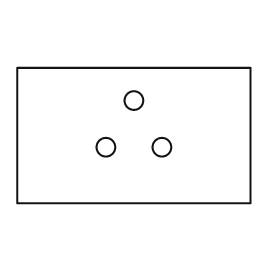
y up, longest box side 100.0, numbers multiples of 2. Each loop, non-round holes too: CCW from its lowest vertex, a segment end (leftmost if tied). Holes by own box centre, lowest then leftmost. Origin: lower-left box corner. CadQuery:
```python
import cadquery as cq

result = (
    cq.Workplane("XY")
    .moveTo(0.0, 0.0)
    .lineTo(100.0, 0.0)
    .lineTo(100.0, 58.0)
    .lineTo(0.0, 58.0)
    .close()
    .moveTo(38.0, 24.0)
    .circle(4.0)
    .moveTo(62.0, 24.0)
    .circle(4.0)
    .moveTo(50.0, 44.0)
    .circle(4.0)
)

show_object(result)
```